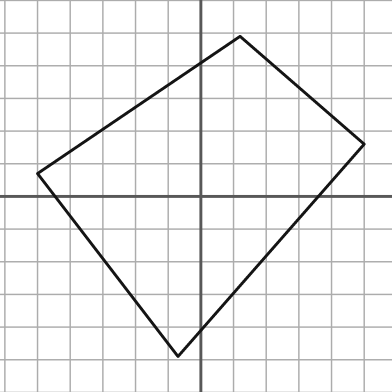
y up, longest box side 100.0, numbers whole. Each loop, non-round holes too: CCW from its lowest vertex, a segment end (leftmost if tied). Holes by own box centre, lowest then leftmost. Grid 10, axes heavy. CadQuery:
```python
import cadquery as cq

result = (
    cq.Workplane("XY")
    .moveTo(-7.0, -49.0)
    .lineTo(50.0, 16.0)
    .lineTo(12.0, 49.0)
    .lineTo(-50.0, 7.0)
    .close()
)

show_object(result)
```